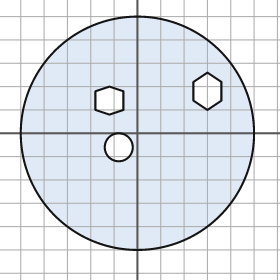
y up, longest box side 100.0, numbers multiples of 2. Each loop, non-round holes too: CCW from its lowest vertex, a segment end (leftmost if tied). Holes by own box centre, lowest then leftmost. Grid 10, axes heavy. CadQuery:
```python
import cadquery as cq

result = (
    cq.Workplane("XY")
    .moveTo(0.0, 0.0)
    .circle(50.0)
    .moveTo(-8.0, -6.0)
    .circle(6.0)
    .moveTo(-12.0, 8.0)
    .lineTo(-6.0, 10.0)
    .lineTo(-6.0, 18.0)
    .lineTo(-12.0, 20.0)
    .lineTo(-18.0, 18.0)
    .lineTo(-18.0, 10.0)
    .close()
    .moveTo(30.0, 10.0)
    .lineTo(36.0, 14.0)
    .lineTo(36.0, 22.0)
    .lineTo(30.0, 26.0)
    .lineTo(24.0, 22.0)
    .lineTo(24.0, 14.0)
    .close()
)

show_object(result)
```